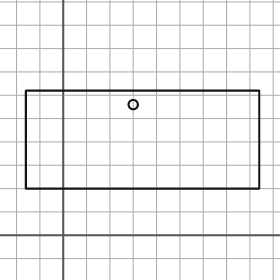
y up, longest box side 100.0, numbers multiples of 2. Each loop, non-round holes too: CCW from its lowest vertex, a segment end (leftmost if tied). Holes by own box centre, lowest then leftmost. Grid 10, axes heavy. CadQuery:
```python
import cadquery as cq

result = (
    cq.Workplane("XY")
    .moveTo(-16.0, 20.0)
    .lineTo(84.0, 20.0)
    .lineTo(84.0, 62.0)
    .lineTo(-16.0, 62.0)
    .close()
    .moveTo(30.0, 56.0)
    .circle(2.0)
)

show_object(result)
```